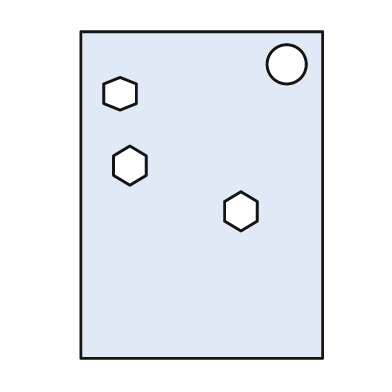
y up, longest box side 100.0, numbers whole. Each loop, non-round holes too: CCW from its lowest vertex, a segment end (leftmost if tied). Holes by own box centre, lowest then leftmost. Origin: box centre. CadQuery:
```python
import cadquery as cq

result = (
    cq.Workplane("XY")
    .moveTo(-37.0, -50.0)
    .lineTo(37.0, -50.0)
    .lineTo(37.0, 50.0)
    .lineTo(-37.0, 50.0)
    .close()
    .moveTo(12.0, -11.0)
    .lineTo(17.0, -8.0)
    .lineTo(17.0, -2.0)
    .lineTo(12.0, 1.0)
    .lineTo(7.0, -2.0)
    .lineTo(7.0, -8.0)
    .close()
    .moveTo(-22.0, 3.0)
    .lineTo(-17.0, 6.0)
    .lineTo(-17.0, 12.0)
    .lineTo(-22.0, 15.0)
    .lineTo(-27.0, 12.0)
    .lineTo(-27.0, 6.0)
    .close()
    .moveTo(-25.0, 26.0)
    .lineTo(-20.0, 28.0)
    .lineTo(-20.0, 34.0)
    .lineTo(-25.0, 36.0)
    .lineTo(-30.0, 34.0)
    .lineTo(-30.0, 28.0)
    .close()
    .moveTo(26.0, 40.0)
    .circle(6.0)
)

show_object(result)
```